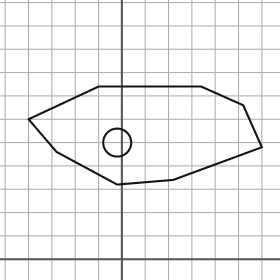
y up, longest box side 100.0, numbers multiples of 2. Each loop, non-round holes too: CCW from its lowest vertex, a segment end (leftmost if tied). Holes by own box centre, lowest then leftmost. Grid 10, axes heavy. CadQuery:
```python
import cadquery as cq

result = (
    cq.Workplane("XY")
    .moveTo(-2.0, 32.0)
    .lineTo(22.0, 34.0)
    .lineTo(60.0, 48.0)
    .lineTo(52.0, 66.0)
    .lineTo(34.0, 74.0)
    .lineTo(-10.0, 74.0)
    .lineTo(-40.0, 60.0)
    .lineTo(-28.0, 46.0)
    .close()
    .moveTo(-2.0, 50.0)
    .circle(6.0)
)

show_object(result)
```